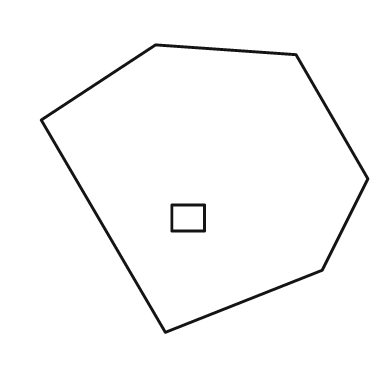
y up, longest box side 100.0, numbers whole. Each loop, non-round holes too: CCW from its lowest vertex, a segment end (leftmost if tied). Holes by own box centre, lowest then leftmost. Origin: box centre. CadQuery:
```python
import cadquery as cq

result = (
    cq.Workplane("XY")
    .moveTo(-12.0, -44.0)
    .lineTo(36.0, -25.0)
    .lineTo(50.0, 3.0)
    .lineTo(28.0, 41.0)
    .lineTo(-15.0, 44.0)
    .lineTo(-50.0, 21.0)
    .close()
    .moveTo(-10.0, -13.0)
    .lineTo(0.0, -13.0)
    .lineTo(0.0, -5.0)
    .lineTo(-10.0, -5.0)
    .close()
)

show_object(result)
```